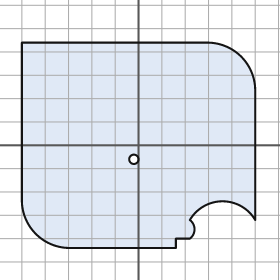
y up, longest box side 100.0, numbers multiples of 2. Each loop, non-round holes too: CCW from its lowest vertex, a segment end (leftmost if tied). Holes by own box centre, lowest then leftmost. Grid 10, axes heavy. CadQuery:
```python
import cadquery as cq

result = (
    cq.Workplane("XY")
    .moveTo(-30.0, -44.0)
    .lineTo(16.0, -44.0)
    .lineTo(16.0, -40.0)
    .lineTo(22.0, -40.0)
    .threePointArc((24.0, -36.0), (22.0, -32.0))
    .threePointArc((36.0, -24.0), (50.0, -32.0))
    .lineTo(50.0, 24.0)
    .threePointArc((44.0, 38.0), (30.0, 44.0))
    .lineTo(-50.0, 44.0)
    .lineTo(-50.0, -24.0)
    .threePointArc((-44.0, -38.0), (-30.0, -44.0))
    .close()
    .moveTo(-2.0, -6.0)
    .circle(2.0)
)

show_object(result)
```